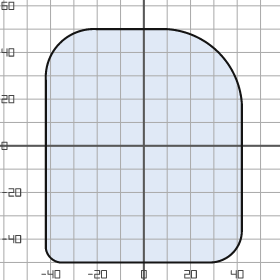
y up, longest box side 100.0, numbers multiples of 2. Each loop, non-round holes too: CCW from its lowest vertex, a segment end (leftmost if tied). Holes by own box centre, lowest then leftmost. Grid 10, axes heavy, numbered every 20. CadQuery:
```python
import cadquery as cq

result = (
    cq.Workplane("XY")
    .moveTo(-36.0, -50.0)
    .lineTo(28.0, -50.0)
    .threePointArc((38.0, -46.0), (42.0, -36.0))
    .lineTo(42.0, 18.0)
    .threePointArc((32.0, 40.0), (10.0, 50.0))
    .lineTo(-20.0, 50.0)
    .threePointArc((-36.0, 44.0), (-42.0, 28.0))
    .lineTo(-42.0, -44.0)
    .threePointArc((-40.0, -48.0), (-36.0, -50.0))
    .close()
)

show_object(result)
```